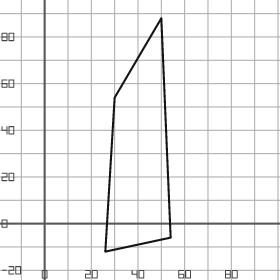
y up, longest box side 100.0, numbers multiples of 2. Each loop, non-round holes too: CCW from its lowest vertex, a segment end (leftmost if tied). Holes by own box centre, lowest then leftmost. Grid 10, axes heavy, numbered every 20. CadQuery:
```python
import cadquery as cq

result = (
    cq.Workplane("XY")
    .moveTo(26.0, -12.0)
    .lineTo(54.0, -6.0)
    .lineTo(50.0, 88.0)
    .lineTo(30.0, 54.0)
    .close()
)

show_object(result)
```